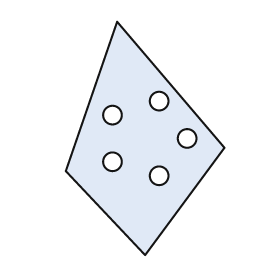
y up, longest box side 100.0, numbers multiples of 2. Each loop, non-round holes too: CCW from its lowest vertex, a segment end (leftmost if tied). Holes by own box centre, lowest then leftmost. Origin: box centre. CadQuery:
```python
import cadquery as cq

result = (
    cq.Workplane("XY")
    .moveTo(0.0, -50.0)
    .lineTo(34.0, -4.0)
    .lineTo(-12.0, 50.0)
    .lineTo(-34.0, -14.0)
    .close()
    .moveTo(6.0, -16.0)
    .circle(4.0)
    .moveTo(-14.0, -10.0)
    .circle(4.0)
    .moveTo(18.0, 0.0)
    .circle(4.0)
    .moveTo(-14.0, 10.0)
    .circle(4.0)
    .moveTo(6.0, 16.0)
    .circle(4.0)
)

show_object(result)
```